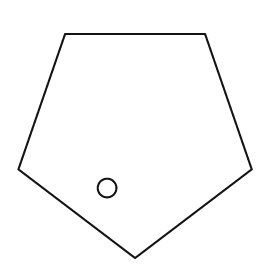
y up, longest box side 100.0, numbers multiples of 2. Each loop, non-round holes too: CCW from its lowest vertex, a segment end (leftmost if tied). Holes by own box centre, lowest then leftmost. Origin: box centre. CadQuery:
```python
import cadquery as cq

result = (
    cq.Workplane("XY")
    .moveTo(0.0, -48.0)
    .lineTo(50.0, -10.0)
    .lineTo(30.0, 48.0)
    .lineTo(-30.0, 48.0)
    .lineTo(-50.0, -10.0)
    .close()
    .moveTo(-12.0, -18.0)
    .circle(4.0)
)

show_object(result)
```